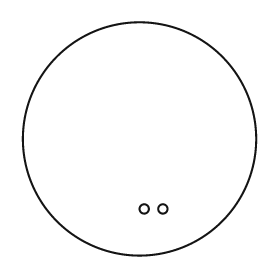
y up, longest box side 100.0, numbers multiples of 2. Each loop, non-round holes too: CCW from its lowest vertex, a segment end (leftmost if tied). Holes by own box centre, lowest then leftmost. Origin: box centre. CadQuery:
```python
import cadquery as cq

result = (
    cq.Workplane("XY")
    .moveTo(0.0, 0.0)
    .circle(50.0)
    .moveTo(2.0, -30.0)
    .circle(2.0)
    .moveTo(10.0, -30.0)
    .circle(2.0)
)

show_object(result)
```